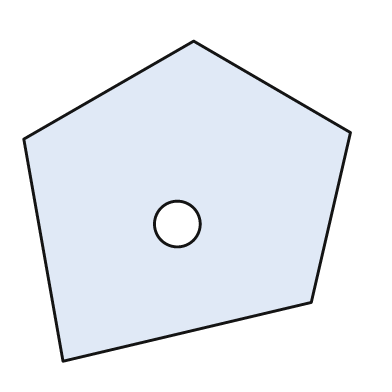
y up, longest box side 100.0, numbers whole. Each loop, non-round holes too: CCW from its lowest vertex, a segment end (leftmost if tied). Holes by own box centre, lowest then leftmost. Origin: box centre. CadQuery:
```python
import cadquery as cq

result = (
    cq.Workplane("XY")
    .moveTo(-38.0, -49.0)
    .lineTo(38.0, -31.0)
    .lineTo(50.0, 21.0)
    .lineTo(2.0, 49.0)
    .lineTo(-50.0, 19.0)
    .close()
    .moveTo(-3.0, -7.0)
    .circle(7.0)
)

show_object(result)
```